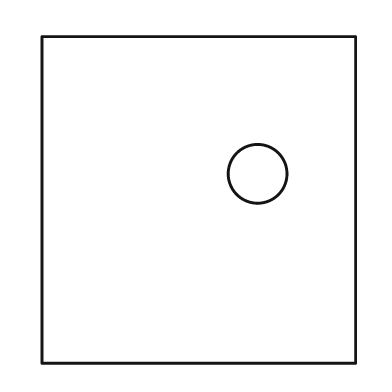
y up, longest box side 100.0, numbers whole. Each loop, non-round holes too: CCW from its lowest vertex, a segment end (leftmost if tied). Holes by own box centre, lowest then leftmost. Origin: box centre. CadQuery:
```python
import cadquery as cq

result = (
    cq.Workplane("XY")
    .moveTo(-48.0, -50.0)
    .lineTo(48.0, -50.0)
    .lineTo(48.0, 50.0)
    .lineTo(-48.0, 50.0)
    .close()
    .moveTo(18.0, 8.0)
    .circle(9.0)
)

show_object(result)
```